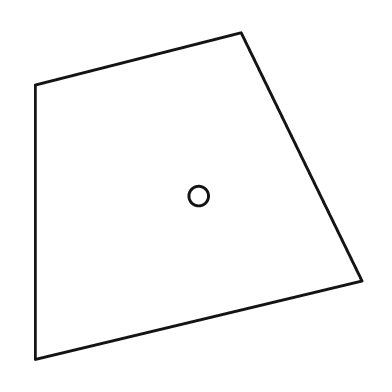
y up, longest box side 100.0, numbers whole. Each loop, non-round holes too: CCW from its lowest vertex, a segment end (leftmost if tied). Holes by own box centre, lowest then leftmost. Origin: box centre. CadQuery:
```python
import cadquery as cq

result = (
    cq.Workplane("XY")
    .moveTo(-50.0, -50.0)
    .lineTo(50.0, -26.0)
    .lineTo(13.0, 50.0)
    .lineTo(-50.0, 34.0)
    .close()
    .moveTo(0.0, 0.0)
    .circle(3.0)
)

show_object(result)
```